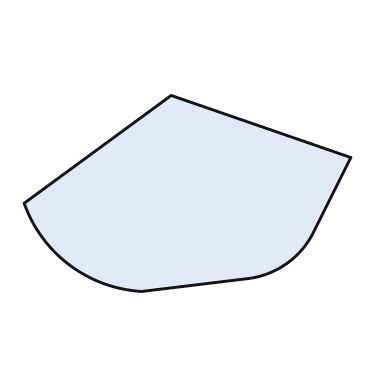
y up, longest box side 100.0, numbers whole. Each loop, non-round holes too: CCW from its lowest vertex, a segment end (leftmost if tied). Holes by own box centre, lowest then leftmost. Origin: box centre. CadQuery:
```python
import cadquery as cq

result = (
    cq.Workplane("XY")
    .moveTo(-14.0, -30.0)
    .lineTo(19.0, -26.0)
    .threePointArc((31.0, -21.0), (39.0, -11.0))
    .lineTo(50.0, 11.0)
    .lineTo(-5.0, 30.0)
    .lineTo(-50.0, -3.0)
    .threePointArc((-36.0, -22.0), (-14.0, -30.0))
    .close()
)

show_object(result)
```